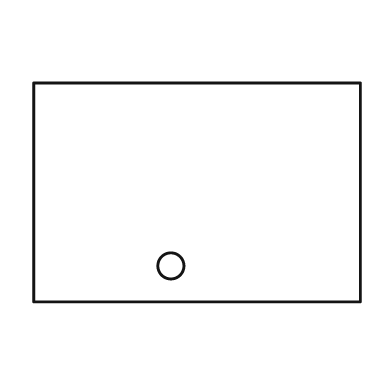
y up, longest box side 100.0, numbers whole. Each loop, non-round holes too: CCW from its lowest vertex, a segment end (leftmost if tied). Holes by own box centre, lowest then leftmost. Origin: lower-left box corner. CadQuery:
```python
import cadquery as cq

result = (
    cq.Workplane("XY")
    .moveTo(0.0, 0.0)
    .lineTo(100.0, 0.0)
    .lineTo(100.0, 67.0)
    .lineTo(0.0, 67.0)
    .close()
    .moveTo(42.0, 11.0)
    .circle(4.0)
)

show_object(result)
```